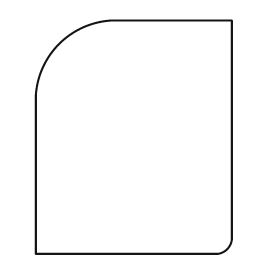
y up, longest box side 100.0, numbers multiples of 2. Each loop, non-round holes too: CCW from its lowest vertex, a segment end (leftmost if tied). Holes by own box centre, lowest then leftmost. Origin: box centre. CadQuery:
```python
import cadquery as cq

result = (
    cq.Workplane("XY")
    .moveTo(-42.0, -50.0)
    .lineTo(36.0, -50.0)
    .threePointArc((40.0, -48.0), (42.0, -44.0))
    .lineTo(42.0, 50.0)
    .lineTo(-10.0, 50.0)
    .threePointArc((-32.0, 40.0), (-42.0, 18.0))
    .close()
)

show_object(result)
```